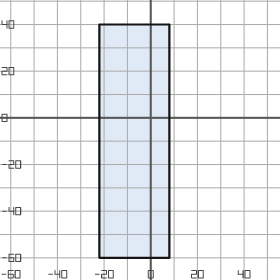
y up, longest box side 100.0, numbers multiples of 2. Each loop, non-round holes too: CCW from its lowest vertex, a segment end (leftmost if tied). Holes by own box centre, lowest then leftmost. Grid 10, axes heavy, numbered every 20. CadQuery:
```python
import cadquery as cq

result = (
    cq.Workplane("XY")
    .moveTo(-22.0, -60.0)
    .lineTo(8.0, -60.0)
    .lineTo(8.0, 40.0)
    .lineTo(-22.0, 40.0)
    .close()
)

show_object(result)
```